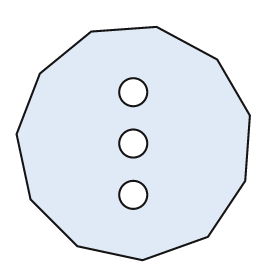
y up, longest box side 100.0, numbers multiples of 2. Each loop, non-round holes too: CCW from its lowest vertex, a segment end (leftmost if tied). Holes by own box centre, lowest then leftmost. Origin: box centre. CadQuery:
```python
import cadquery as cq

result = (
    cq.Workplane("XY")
    .moveTo(4.0, -50.0)
    .lineTo(32.0, -40.0)
    .lineTo(48.0, -16.0)
    .lineTo(50.0, 12.0)
    .lineTo(36.0, 36.0)
    .lineTo(10.0, 50.0)
    .lineTo(-18.0, 48.0)
    .lineTo(-40.0, 30.0)
    .lineTo(-50.0, 4.0)
    .lineTo(-44.0, -24.0)
    .lineTo(-24.0, -44.0)
    .close()
    .moveTo(0.0, -22.0)
    .circle(6.0)
    .moveTo(0.0, 0.0)
    .circle(6.0)
    .moveTo(0.0, 22.0)
    .circle(6.0)
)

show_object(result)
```